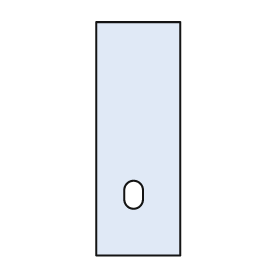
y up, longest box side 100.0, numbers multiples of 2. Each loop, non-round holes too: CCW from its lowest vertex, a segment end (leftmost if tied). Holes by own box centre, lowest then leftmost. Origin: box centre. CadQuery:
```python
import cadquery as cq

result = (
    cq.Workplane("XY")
    .moveTo(-18.0, -50.0)
    .lineTo(18.0, -50.0)
    .lineTo(18.0, 50.0)
    .lineTo(-18.0, 50.0)
    .close()
    .moveTo(-6.0, -26.0)
    .threePointArc((-2.0, -30.0), (2.0, -26.0))
    .lineTo(2.0, -22.0)
    .threePointArc((-2.0, -18.0), (-6.0, -22.0))
    .close()
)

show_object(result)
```